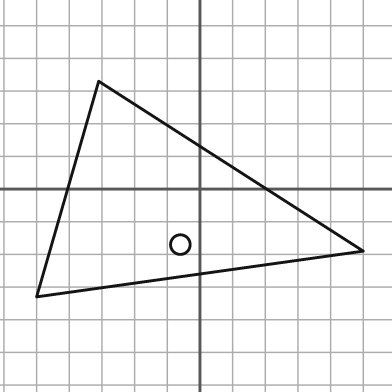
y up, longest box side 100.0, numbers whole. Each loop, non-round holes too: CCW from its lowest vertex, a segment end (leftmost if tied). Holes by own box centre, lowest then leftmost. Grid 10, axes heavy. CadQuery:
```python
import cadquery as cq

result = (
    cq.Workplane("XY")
    .moveTo(-50.0, -33.0)
    .lineTo(50.0, -19.0)
    .lineTo(-31.0, 33.0)
    .close()
    .moveTo(-6.0, -17.0)
    .circle(3.0)
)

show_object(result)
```